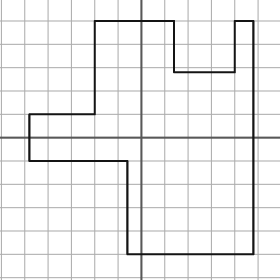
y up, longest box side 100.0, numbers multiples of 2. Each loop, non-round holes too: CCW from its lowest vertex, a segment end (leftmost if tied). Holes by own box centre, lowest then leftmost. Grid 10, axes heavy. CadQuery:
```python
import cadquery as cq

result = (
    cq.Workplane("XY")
    .moveTo(-6.0, -50.0)
    .lineTo(48.0, -50.0)
    .lineTo(48.0, 50.0)
    .lineTo(40.0, 50.0)
    .lineTo(40.0, 28.0)
    .lineTo(14.0, 28.0)
    .lineTo(14.0, 50.0)
    .lineTo(-20.0, 50.0)
    .lineTo(-20.0, 10.0)
    .lineTo(-48.0, 10.0)
    .lineTo(-48.0, -10.0)
    .lineTo(-6.0, -10.0)
    .close()
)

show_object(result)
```